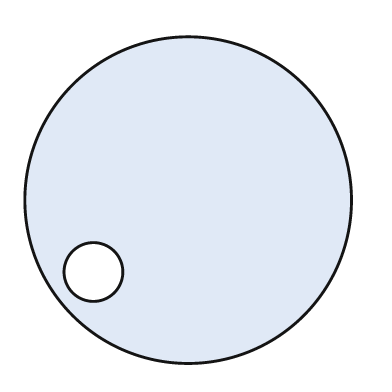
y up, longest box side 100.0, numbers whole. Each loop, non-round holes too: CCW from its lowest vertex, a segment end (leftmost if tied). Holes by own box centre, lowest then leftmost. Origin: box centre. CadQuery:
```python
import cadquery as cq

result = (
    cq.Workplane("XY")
    .moveTo(0.0, 0.0)
    .circle(50.0)
    .moveTo(-29.0, -22.0)
    .circle(9.0)
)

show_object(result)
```